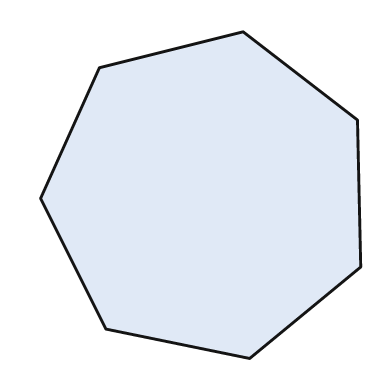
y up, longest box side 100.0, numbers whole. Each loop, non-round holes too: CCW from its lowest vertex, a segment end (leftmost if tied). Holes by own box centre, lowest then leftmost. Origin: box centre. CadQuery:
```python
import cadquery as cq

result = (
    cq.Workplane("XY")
    .moveTo(15.0, -50.0)
    .lineTo(49.0, -22.0)
    .lineTo(48.0, 23.0)
    .lineTo(13.0, 50.0)
    .lineTo(-31.0, 39.0)
    .lineTo(-49.0, -1.0)
    .lineTo(-29.0, -41.0)
    .close()
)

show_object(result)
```